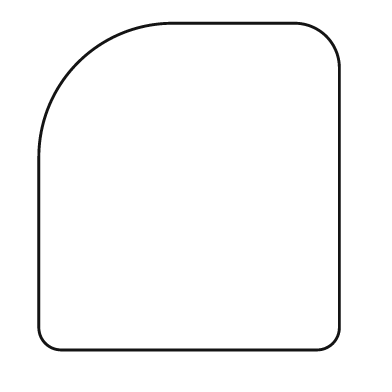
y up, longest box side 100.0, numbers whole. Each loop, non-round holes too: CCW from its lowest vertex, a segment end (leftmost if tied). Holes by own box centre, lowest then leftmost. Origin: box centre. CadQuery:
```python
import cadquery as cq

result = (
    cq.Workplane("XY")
    .moveTo(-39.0, -50.0)
    .lineTo(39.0, -50.0)
    .threePointArc((44.0, -48.0), (46.0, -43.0))
    .lineTo(46.0, 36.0)
    .threePointArc((42.0, 46.0), (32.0, 50.0))
    .lineTo(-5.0, 50.0)
    .threePointArc((-34.0, 38.0), (-46.0, 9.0))
    .lineTo(-46.0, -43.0)
    .threePointArc((-44.0, -48.0), (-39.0, -50.0))
    .close()
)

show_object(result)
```